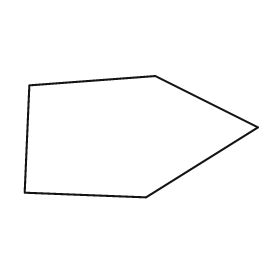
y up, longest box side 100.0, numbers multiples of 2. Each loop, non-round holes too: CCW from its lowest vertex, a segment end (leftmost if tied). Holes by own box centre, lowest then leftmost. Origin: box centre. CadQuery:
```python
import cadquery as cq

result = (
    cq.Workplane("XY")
    .moveTo(2.0, -26.0)
    .lineTo(50.0, 4.0)
    .lineTo(6.0, 26.0)
    .lineTo(-48.0, 22.0)
    .lineTo(-50.0, -24.0)
    .close()
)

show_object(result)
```